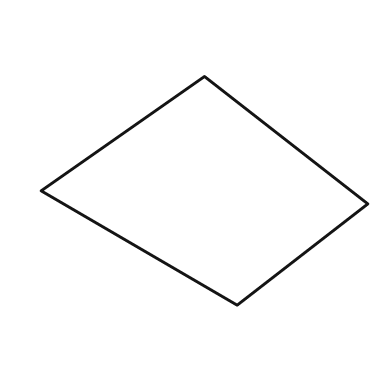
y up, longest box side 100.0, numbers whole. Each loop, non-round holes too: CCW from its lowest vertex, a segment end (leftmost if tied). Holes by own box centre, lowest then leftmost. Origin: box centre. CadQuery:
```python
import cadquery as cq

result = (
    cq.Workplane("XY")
    .moveTo(10.0, -35.0)
    .lineTo(50.0, -4.0)
    .lineTo(0.0, 35.0)
    .lineTo(-50.0, 0.0)
    .close()
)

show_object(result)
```